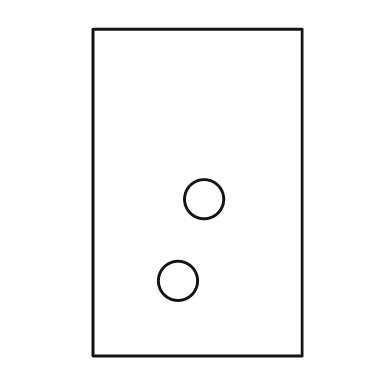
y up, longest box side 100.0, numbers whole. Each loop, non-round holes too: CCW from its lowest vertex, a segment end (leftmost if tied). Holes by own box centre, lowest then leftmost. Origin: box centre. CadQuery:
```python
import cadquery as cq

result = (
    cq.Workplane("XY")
    .moveTo(-32.0, -50.0)
    .lineTo(32.0, -50.0)
    .lineTo(32.0, 50.0)
    .lineTo(-32.0, 50.0)
    .close()
    .moveTo(-6.0, -27.0)
    .circle(6.0)
    .moveTo(2.0, -2.0)
    .circle(6.0)
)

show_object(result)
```